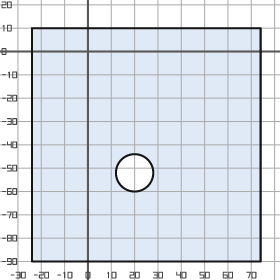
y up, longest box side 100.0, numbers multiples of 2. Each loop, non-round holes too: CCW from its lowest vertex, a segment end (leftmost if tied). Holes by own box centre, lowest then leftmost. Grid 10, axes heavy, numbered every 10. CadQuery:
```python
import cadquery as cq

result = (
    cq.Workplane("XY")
    .moveTo(-24.0, -90.0)
    .lineTo(74.0, -90.0)
    .lineTo(74.0, 10.0)
    .lineTo(-24.0, 10.0)
    .close()
    .moveTo(20.0, -52.0)
    .circle(8.0)
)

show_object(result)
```